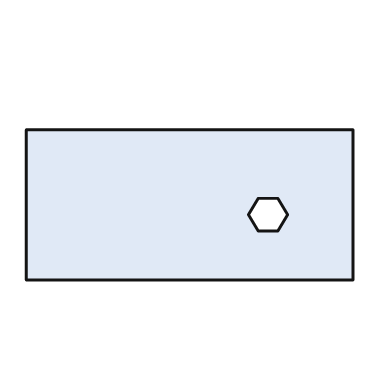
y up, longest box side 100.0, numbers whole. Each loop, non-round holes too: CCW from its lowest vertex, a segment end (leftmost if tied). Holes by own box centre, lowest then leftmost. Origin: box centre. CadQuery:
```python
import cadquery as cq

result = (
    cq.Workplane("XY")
    .moveTo(-50.0, -23.0)
    .lineTo(50.0, -23.0)
    .lineTo(50.0, 23.0)
    .lineTo(-50.0, 23.0)
    .close()
    .moveTo(21.0, -8.0)
    .lineTo(27.0, -8.0)
    .lineTo(30.0, -3.0)
    .lineTo(27.0, 2.0)
    .lineTo(21.0, 2.0)
    .lineTo(18.0, -3.0)
    .close()
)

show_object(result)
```